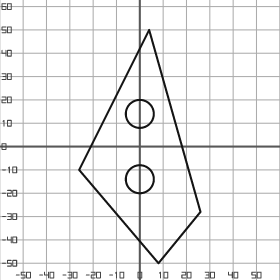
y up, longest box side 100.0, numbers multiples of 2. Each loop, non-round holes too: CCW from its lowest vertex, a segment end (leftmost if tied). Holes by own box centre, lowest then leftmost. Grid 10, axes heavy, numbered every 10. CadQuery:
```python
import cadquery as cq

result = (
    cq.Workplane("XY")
    .moveTo(8.0, -50.0)
    .lineTo(26.0, -28.0)
    .lineTo(4.0, 50.0)
    .lineTo(-26.0, -10.0)
    .close()
    .moveTo(0.0, -14.0)
    .circle(6.0)
    .moveTo(0.0, 14.0)
    .circle(6.0)
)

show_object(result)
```